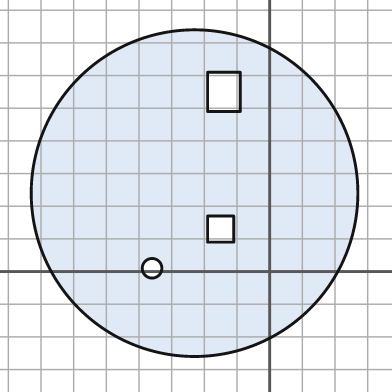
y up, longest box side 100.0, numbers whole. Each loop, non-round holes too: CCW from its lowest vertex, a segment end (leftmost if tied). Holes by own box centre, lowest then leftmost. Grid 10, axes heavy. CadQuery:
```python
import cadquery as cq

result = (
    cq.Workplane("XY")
    .moveTo(-23.0, 24.0)
    .circle(50.0)
    .moveTo(-36.0, 1.0)
    .circle(3.0)
    .moveTo(-19.0, 9.0)
    .lineTo(-11.0, 9.0)
    .lineTo(-11.0, 17.0)
    .lineTo(-19.0, 17.0)
    .close()
    .moveTo(-19.0, 49.0)
    .lineTo(-9.0, 49.0)
    .lineTo(-9.0, 61.0)
    .lineTo(-19.0, 61.0)
    .close()
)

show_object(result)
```